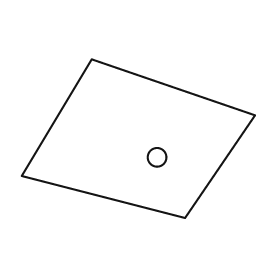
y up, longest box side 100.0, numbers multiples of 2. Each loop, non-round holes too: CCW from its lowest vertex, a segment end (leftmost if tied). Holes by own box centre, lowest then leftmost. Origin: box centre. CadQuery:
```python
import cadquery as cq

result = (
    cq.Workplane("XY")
    .moveTo(20.0, -34.0)
    .lineTo(50.0, 10.0)
    .lineTo(-20.0, 34.0)
    .lineTo(-50.0, -16.0)
    .close()
    .moveTo(8.0, -8.0)
    .circle(4.0)
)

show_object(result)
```